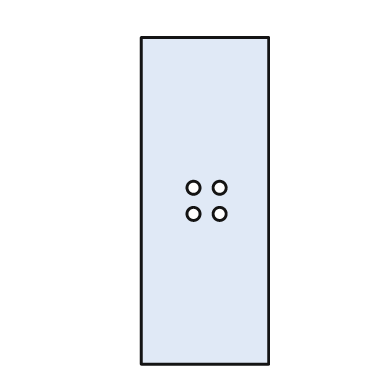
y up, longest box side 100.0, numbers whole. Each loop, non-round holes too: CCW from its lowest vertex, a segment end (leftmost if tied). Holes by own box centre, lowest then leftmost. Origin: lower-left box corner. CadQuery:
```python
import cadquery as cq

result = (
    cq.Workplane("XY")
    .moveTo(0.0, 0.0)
    .lineTo(39.0, 0.0)
    .lineTo(39.0, 100.0)
    .lineTo(0.0, 100.0)
    .close()
    .moveTo(16.0, 46.0)
    .circle(2.0)
    .moveTo(24.0, 46.0)
    .circle(2.0)
    .moveTo(16.0, 54.0)
    .circle(2.0)
    .moveTo(24.0, 54.0)
    .circle(2.0)
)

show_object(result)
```